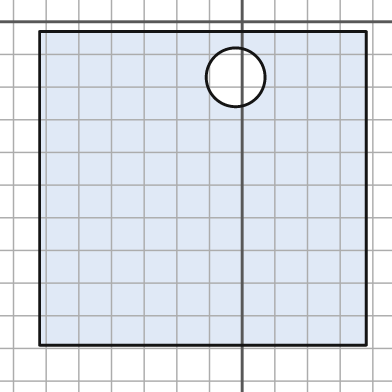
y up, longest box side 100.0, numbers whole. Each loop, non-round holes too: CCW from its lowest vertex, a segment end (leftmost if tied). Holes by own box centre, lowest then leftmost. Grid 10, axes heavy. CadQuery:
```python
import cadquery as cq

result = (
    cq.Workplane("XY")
    .moveTo(-62.0, -99.0)
    .lineTo(38.0, -99.0)
    .lineTo(38.0, -3.0)
    .lineTo(-62.0, -3.0)
    .close()
    .moveTo(-2.0, -17.0)
    .circle(9.0)
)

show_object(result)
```